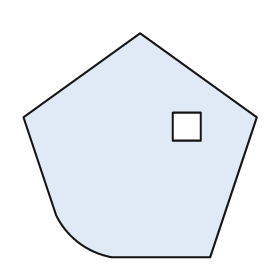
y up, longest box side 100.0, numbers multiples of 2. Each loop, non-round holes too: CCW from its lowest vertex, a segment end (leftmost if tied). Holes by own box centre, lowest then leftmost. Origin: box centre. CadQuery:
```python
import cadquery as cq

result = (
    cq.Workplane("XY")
    .moveTo(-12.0, -48.0)
    .lineTo(30.0, -48.0)
    .lineTo(50.0, 12.0)
    .lineTo(0.0, 48.0)
    .lineTo(-50.0, 12.0)
    .lineTo(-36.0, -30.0)
    .threePointArc((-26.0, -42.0), (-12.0, -48.0))
    .close()
    .moveTo(14.0, 2.0)
    .lineTo(26.0, 2.0)
    .lineTo(26.0, 14.0)
    .lineTo(14.0, 14.0)
    .close()
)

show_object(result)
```